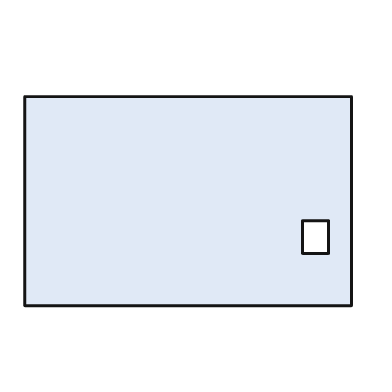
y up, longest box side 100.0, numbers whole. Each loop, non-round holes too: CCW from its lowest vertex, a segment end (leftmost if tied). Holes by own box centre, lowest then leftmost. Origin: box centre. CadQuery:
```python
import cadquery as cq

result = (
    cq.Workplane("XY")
    .moveTo(-50.0, -32.0)
    .lineTo(50.0, -32.0)
    .lineTo(50.0, 32.0)
    .lineTo(-50.0, 32.0)
    .close()
    .moveTo(35.0, -16.0)
    .lineTo(43.0, -16.0)
    .lineTo(43.0, -6.0)
    .lineTo(35.0, -6.0)
    .close()
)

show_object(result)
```